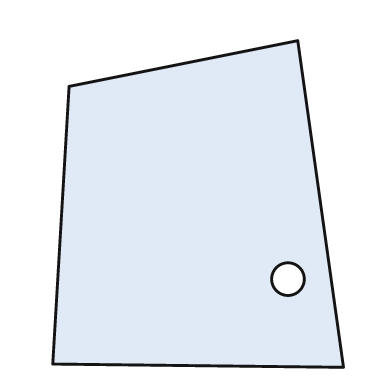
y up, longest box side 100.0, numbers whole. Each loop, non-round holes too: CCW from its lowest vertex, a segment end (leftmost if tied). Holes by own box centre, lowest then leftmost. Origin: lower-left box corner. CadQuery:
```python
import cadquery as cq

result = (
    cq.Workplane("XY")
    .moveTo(89.0, 0.0)
    .lineTo(75.0, 100.0)
    .lineTo(5.0, 86.0)
    .lineTo(0.0, 1.0)
    .close()
    .moveTo(72.0, 27.0)
    .circle(5.0)
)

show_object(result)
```